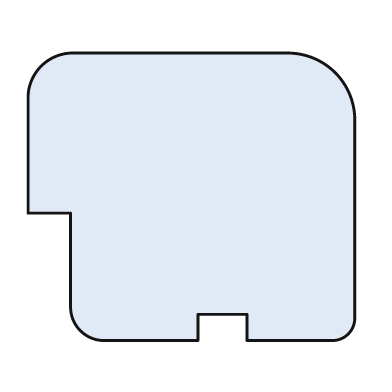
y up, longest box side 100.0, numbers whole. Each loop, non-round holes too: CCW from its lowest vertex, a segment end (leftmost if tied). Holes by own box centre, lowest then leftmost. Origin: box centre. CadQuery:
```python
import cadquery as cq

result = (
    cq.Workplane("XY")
    .moveTo(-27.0, -44.0)
    .lineTo(2.0, -44.0)
    .lineTo(2.0, -36.0)
    .lineTo(17.0, -36.0)
    .lineTo(17.0, -44.0)
    .lineTo(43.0, -44.0)
    .threePointArc((48.0, -42.0), (50.0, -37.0))
    .lineTo(50.0, 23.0)
    .threePointArc((44.0, 38.0), (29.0, 44.0))
    .lineTo(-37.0, 44.0)
    .threePointArc((-46.0, 40.0), (-50.0, 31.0))
    .lineTo(-50.0, -5.0)
    .lineTo(-37.0, -5.0)
    .lineTo(-37.0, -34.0)
    .threePointArc((-34.0, -41.0), (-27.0, -44.0))
    .close()
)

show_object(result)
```